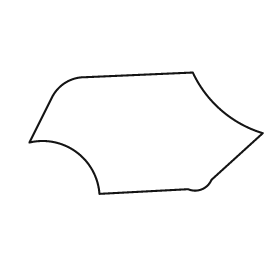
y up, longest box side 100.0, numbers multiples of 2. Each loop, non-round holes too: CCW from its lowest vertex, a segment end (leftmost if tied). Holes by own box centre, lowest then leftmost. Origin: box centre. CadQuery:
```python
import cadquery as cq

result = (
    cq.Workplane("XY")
    .moveTo(-20.0, -26.0)
    .lineTo(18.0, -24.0)
    .threePointArc((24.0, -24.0), (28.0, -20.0))
    .lineTo(50.0, 0.0)
    .threePointArc((32.0, 10.0), (20.0, 26.0))
    .lineTo(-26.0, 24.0)
    .threePointArc((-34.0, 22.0), (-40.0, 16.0))
    .lineTo(-50.0, -4.0)
    .threePointArc((-30.0, -8.0), (-20.0, -26.0))
    .close()
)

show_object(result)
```